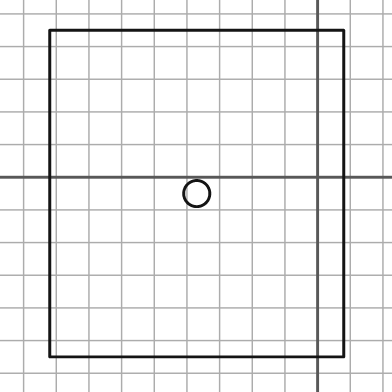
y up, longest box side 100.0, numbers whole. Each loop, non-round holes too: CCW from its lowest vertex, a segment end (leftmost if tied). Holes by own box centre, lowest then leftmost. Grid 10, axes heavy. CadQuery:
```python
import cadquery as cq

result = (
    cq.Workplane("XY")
    .moveTo(-82.0, -55.0)
    .lineTo(8.0, -55.0)
    .lineTo(8.0, 45.0)
    .lineTo(-82.0, 45.0)
    .close()
    .moveTo(-37.0, -5.0)
    .circle(4.0)
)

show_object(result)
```